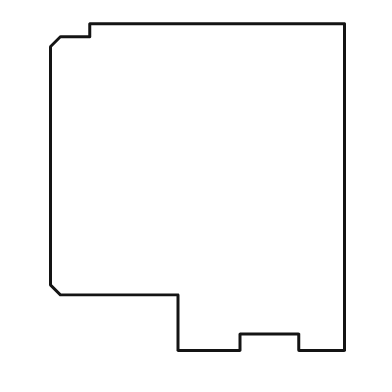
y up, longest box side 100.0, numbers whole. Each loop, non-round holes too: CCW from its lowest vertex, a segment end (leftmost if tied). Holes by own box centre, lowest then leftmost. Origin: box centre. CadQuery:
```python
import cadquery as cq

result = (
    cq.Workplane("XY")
    .moveTo(-6.0, -50.0)
    .lineTo(13.0, -50.0)
    .lineTo(13.0, -45.0)
    .lineTo(31.0, -45.0)
    .lineTo(31.0, -50.0)
    .lineTo(45.0, -50.0)
    .lineTo(45.0, 50.0)
    .lineTo(-33.0, 50.0)
    .lineTo(-33.0, 46.0)
    .lineTo(-42.0, 46.0)
    .lineTo(-45.0, 43.0)
    .lineTo(-45.0, -30.0)
    .lineTo(-42.0, -33.0)
    .lineTo(-6.0, -33.0)
    .close()
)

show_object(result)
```